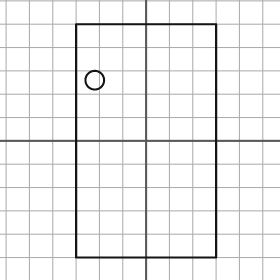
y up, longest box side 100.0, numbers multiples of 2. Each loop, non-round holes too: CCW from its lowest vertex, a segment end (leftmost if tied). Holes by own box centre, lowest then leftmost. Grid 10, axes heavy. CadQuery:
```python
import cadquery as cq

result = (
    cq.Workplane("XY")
    .moveTo(-30.0, -50.0)
    .lineTo(30.0, -50.0)
    .lineTo(30.0, 50.0)
    .lineTo(-30.0, 50.0)
    .close()
    .moveTo(-22.0, 26.0)
    .circle(4.0)
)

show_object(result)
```